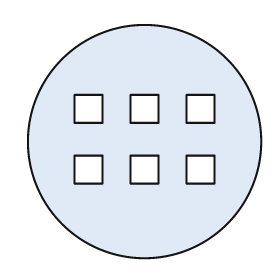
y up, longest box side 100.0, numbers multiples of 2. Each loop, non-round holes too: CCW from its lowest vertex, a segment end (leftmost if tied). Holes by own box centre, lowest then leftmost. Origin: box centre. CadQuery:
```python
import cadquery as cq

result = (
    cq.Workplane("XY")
    .moveTo(0.0, 0.0)
    .circle(50.0)
    .moveTo(-30.0, -18.0)
    .lineTo(-18.0, -18.0)
    .lineTo(-18.0, -6.0)
    .lineTo(-30.0, -6.0)
    .close()
    .moveTo(-6.0, -18.0)
    .lineTo(6.0, -18.0)
    .lineTo(6.0, -6.0)
    .lineTo(-6.0, -6.0)
    .close()
    .moveTo(18.0, -18.0)
    .lineTo(30.0, -18.0)
    .lineTo(30.0, -6.0)
    .lineTo(18.0, -6.0)
    .close()
    .moveTo(-30.0, 8.0)
    .lineTo(-18.0, 8.0)
    .lineTo(-18.0, 20.0)
    .lineTo(-30.0, 20.0)
    .close()
    .moveTo(-6.0, 8.0)
    .lineTo(6.0, 8.0)
    .lineTo(6.0, 20.0)
    .lineTo(-6.0, 20.0)
    .close()
    .moveTo(18.0, 8.0)
    .lineTo(30.0, 8.0)
    .lineTo(30.0, 20.0)
    .lineTo(18.0, 20.0)
    .close()
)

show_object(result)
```